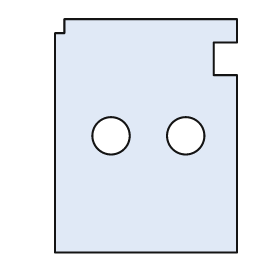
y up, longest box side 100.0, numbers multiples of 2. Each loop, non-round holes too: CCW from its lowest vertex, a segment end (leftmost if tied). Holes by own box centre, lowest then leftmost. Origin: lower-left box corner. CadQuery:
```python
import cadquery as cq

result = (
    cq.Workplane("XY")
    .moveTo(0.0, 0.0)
    .lineTo(78.0, 0.0)
    .lineTo(78.0, 76.0)
    .lineTo(68.0, 76.0)
    .lineTo(68.0, 90.0)
    .lineTo(78.0, 90.0)
    .lineTo(78.0, 100.0)
    .lineTo(4.0, 100.0)
    .lineTo(4.0, 94.0)
    .lineTo(0.0, 94.0)
    .close()
    .moveTo(24.0, 50.0)
    .circle(8.0)
    .moveTo(56.0, 50.0)
    .circle(8.0)
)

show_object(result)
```